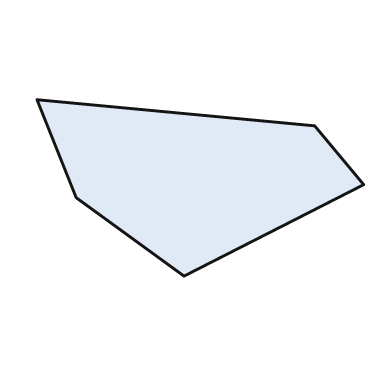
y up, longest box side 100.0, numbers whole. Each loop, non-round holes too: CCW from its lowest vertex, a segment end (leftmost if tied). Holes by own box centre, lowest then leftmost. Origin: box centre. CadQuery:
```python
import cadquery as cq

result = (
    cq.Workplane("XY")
    .moveTo(-5.0, -27.0)
    .lineTo(50.0, 1.0)
    .lineTo(35.0, 19.0)
    .lineTo(-50.0, 27.0)
    .lineTo(-38.0, -3.0)
    .close()
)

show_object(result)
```